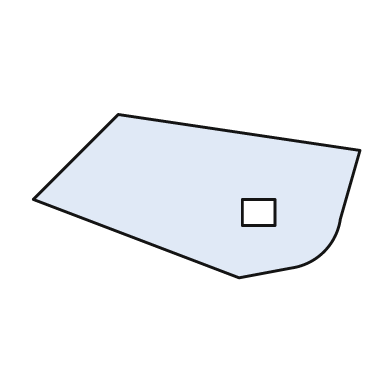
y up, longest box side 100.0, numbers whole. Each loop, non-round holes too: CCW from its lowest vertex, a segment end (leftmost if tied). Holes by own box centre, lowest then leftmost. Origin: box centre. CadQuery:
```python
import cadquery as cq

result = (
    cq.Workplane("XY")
    .moveTo(13.0, -25.0)
    .lineTo(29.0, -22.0)
    .threePointArc((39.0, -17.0), (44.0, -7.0))
    .lineTo(50.0, 14.0)
    .lineTo(-24.0, 25.0)
    .lineTo(-50.0, -1.0)
    .close()
    .moveTo(14.0, -9.0)
    .lineTo(24.0, -9.0)
    .lineTo(24.0, -1.0)
    .lineTo(14.0, -1.0)
    .close()
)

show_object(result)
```